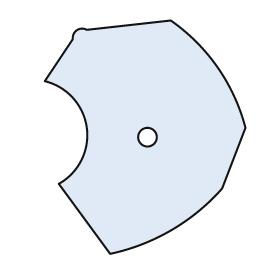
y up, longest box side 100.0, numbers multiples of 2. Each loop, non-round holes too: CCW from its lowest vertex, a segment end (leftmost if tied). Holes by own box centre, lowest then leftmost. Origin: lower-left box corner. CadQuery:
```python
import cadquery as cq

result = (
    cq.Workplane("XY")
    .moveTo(28.0, 0.0)
    .threePointArc((54.0, 10.0), (76.0, 28.0))
    .lineTo(86.0, 54.0)
    .threePointArc((74.0, 80.0), (54.0, 100.0))
    .lineTo(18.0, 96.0)
    .threePointArc((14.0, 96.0), (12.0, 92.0))
    .lineTo(0.0, 74.0)
    .threePointArc((18.0, 54.0), (6.0, 30.0))
    .close()
    .moveTo(44.0, 50.0)
    .circle(4.0)
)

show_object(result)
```